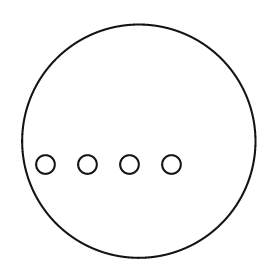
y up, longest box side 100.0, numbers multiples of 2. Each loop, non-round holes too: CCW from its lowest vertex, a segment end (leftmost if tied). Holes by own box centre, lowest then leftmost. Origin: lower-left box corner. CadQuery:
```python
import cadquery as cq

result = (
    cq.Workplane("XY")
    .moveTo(50.0, 50.0)
    .circle(50.0)
    .moveTo(10.0, 40.0)
    .circle(4.0)
    .moveTo(28.0, 40.0)
    .circle(4.0)
    .moveTo(46.0, 40.0)
    .circle(4.0)
    .moveTo(64.0, 40.0)
    .circle(4.0)
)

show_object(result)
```